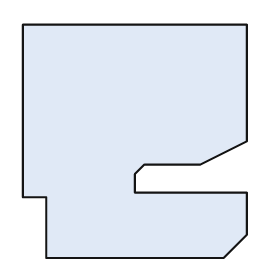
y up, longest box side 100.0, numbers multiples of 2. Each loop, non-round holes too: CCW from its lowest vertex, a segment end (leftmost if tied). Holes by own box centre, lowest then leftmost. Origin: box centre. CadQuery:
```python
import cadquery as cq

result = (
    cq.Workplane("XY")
    .moveTo(-38.0, -50.0)
    .lineTo(38.0, -50.0)
    .lineTo(48.0, -40.0)
    .lineTo(48.0, -22.0)
    .lineTo(0.0, -22.0)
    .lineTo(0.0, -14.0)
    .lineTo(4.0, -10.0)
    .lineTo(28.0, -10.0)
    .lineTo(48.0, 0.0)
    .lineTo(48.0, 50.0)
    .lineTo(-48.0, 50.0)
    .lineTo(-48.0, -24.0)
    .lineTo(-38.0, -24.0)
    .close()
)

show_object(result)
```